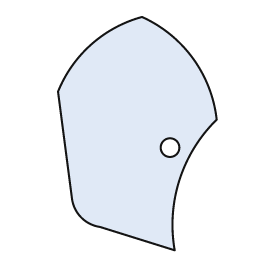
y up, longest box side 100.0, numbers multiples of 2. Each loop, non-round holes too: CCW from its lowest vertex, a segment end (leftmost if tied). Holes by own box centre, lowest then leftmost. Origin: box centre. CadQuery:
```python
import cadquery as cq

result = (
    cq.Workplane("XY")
    .moveTo(16.0, -50.0)
    .threePointArc((18.0, -20.0), (34.0, 6.0))
    .threePointArc((24.0, 32.0), (2.0, 50.0))
    .threePointArc((-20.0, 38.0), (-34.0, 18.0))
    .lineTo(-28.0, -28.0)
    .threePointArc((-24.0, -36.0), (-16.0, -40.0))
    .close()
    .moveTo(14.0, -6.0)
    .circle(4.0)
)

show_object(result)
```